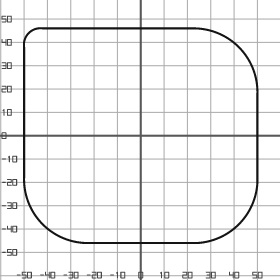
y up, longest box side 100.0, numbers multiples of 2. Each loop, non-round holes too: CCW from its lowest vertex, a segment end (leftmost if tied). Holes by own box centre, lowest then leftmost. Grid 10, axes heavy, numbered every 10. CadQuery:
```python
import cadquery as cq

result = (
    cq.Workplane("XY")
    .moveTo(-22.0, -46.0)
    .lineTo(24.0, -46.0)
    .threePointArc((42.0, -38.0), (50.0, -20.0))
    .lineTo(50.0, 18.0)
    .threePointArc((42.0, 38.0), (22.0, 46.0))
    .lineTo(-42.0, 46.0)
    .threePointArc((-48.0, 44.0), (-50.0, 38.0))
    .lineTo(-50.0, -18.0)
    .threePointArc((-42.0, -38.0), (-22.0, -46.0))
    .close()
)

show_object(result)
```